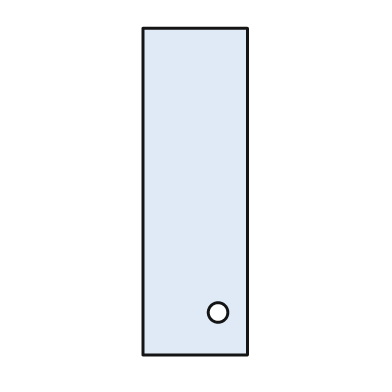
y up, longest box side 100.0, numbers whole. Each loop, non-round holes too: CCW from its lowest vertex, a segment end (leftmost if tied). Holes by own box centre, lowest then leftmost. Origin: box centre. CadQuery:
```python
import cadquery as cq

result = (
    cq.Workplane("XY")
    .moveTo(-16.0, -50.0)
    .lineTo(16.0, -50.0)
    .lineTo(16.0, 50.0)
    .lineTo(-16.0, 50.0)
    .close()
    .moveTo(7.0, -37.0)
    .circle(3.0)
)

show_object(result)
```